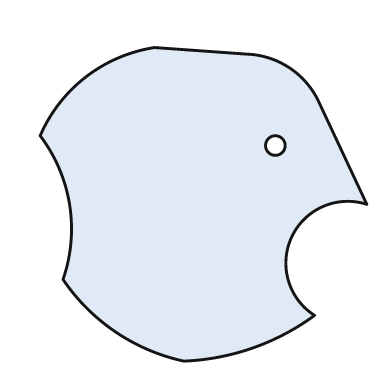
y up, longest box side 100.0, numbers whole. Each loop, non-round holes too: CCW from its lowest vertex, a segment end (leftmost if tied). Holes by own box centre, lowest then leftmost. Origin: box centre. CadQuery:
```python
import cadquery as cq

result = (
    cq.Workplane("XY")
    .moveTo(-6.0, -48.0)
    .threePointArc((15.0, -44.0), (34.0, -34.0))
    .threePointArc((27.0, -10.0), (50.0, 0.0))
    .lineTo(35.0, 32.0)
    .threePointArc((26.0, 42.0), (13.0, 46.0))
    .lineTo(-15.0, 48.0)
    .threePointArc((-36.0, 39.0), (-50.0, 21.0))
    .threePointArc((-41.0, 0.0), (-43.0, -23.0))
    .threePointArc((-27.0, -39.0), (-6.0, -48.0))
    .close()
    .moveTo(22.0, 18.0)
    .circle(3.0)
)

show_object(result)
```